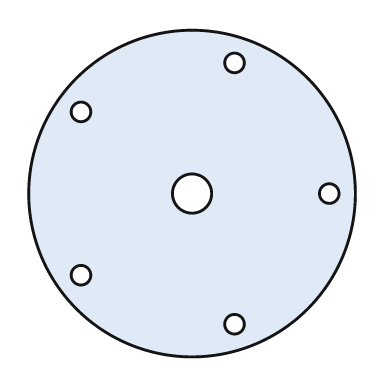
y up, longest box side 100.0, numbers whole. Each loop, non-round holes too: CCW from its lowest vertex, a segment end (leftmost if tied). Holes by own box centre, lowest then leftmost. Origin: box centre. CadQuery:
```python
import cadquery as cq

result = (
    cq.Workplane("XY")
    .moveTo(0.0, 0.0)
    .circle(50.0)
    .moveTo(13.0, -40.0)
    .circle(3.0)
    .moveTo(-34.0, -25.0)
    .circle(3.0)
    .moveTo(0.0, 0.0)
    .circle(6.0)
    .moveTo(42.0, 0.0)
    .circle(3.0)
    .moveTo(-34.0, 25.0)
    .circle(3.0)
    .moveTo(13.0, 40.0)
    .circle(3.0)
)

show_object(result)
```